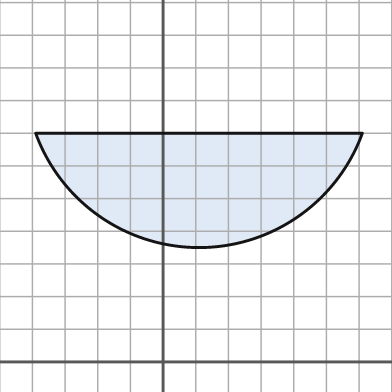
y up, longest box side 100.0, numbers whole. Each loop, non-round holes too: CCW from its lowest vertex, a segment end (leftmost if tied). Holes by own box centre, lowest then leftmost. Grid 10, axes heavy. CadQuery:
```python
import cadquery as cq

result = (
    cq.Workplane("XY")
    .moveTo(-39.0, 70.0)
    .threePointArc((11.0, 35.0), (61.0, 70.0))
    .close()
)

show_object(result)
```